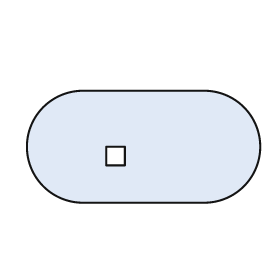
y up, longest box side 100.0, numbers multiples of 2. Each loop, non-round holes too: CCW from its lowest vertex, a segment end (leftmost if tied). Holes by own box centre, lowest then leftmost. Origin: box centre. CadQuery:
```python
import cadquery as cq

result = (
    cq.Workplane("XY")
    .moveTo(-26.0, -24.0)
    .lineTo(26.0, -24.0)
    .threePointArc((50.0, 0.0), (26.0, 24.0))
    .lineTo(-26.0, 24.0)
    .threePointArc((-50.0, 0.0), (-26.0, -24.0))
    .close()
    .moveTo(-16.0, -8.0)
    .lineTo(-8.0, -8.0)
    .lineTo(-8.0, 0.0)
    .lineTo(-16.0, 0.0)
    .close()
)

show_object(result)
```